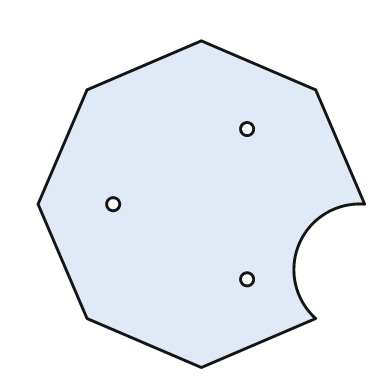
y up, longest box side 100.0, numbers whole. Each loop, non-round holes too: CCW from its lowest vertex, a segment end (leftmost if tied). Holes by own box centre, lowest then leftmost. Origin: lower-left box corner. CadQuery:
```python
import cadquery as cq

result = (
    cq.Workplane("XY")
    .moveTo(50.0, 0.0)
    .lineTo(85.0, 15.0)
    .threePointArc((80.0, 38.0), (100.0, 50.0))
    .lineTo(85.0, 85.0)
    .lineTo(50.0, 100.0)
    .lineTo(15.0, 85.0)
    .lineTo(0.0, 50.0)
    .lineTo(15.0, 15.0)
    .close()
    .moveTo(64.0, 27.0)
    .circle(2.0)
    .moveTo(23.0, 50.0)
    .circle(2.0)
    .moveTo(64.0, 73.0)
    .circle(2.0)
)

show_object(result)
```